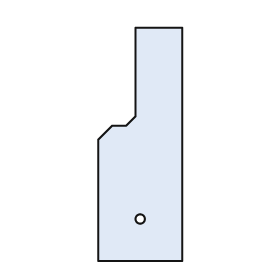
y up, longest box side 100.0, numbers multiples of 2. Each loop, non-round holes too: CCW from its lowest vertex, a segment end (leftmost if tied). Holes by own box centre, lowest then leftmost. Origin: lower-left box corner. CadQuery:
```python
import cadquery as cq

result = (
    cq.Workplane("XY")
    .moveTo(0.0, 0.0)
    .lineTo(36.0, 0.0)
    .lineTo(36.0, 100.0)
    .lineTo(16.0, 100.0)
    .lineTo(16.0, 62.0)
    .lineTo(12.0, 58.0)
    .lineTo(6.0, 58.0)
    .lineTo(0.0, 52.0)
    .close()
    .moveTo(18.0, 18.0)
    .circle(2.0)
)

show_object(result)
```